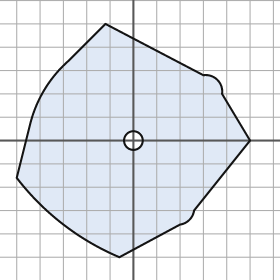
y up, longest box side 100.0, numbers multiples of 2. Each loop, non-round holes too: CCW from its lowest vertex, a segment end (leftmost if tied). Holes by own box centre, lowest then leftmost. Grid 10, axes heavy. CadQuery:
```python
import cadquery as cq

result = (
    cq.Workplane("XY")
    .moveTo(-6.0, -50.0)
    .lineTo(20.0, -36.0)
    .threePointArc((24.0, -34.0), (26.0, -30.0))
    .lineTo(50.0, 0.0)
    .lineTo(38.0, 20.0)
    .threePointArc((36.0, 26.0), (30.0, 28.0))
    .lineTo(-12.0, 50.0)
    .lineTo(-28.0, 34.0)
    .threePointArc((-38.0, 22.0), (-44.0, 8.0))
    .lineTo(-50.0, -16.0)
    .threePointArc((-30.0, -36.0), (-6.0, -50.0))
    .close()
    .moveTo(0.0, 0.0)
    .circle(4.0)
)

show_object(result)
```